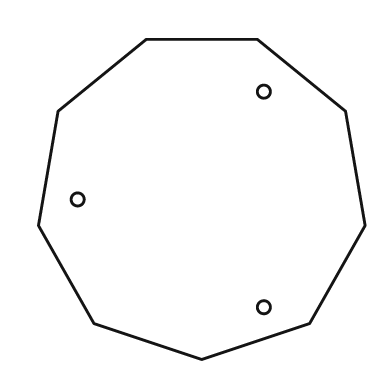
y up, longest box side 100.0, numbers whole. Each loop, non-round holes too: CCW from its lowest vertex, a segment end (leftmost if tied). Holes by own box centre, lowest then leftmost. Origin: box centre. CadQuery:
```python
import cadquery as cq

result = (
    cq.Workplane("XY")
    .moveTo(0.0, -49.0)
    .lineTo(33.0, -38.0)
    .lineTo(50.0, -8.0)
    .lineTo(44.0, 27.0)
    .lineTo(17.0, 49.0)
    .lineTo(-17.0, 49.0)
    .lineTo(-44.0, 27.0)
    .lineTo(-50.0, -8.0)
    .lineTo(-33.0, -38.0)
    .close()
    .moveTo(19.0, -33.0)
    .circle(2.0)
    .moveTo(-38.0, 0.0)
    .circle(2.0)
    .moveTo(19.0, 33.0)
    .circle(2.0)
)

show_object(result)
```